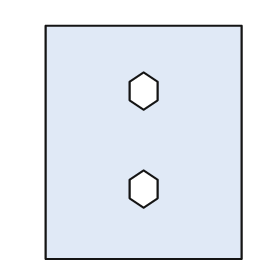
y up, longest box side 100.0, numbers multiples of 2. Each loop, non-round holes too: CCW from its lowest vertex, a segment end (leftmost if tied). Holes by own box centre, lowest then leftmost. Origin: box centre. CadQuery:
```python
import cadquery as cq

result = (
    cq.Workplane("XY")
    .moveTo(-42.0, -50.0)
    .lineTo(42.0, -50.0)
    .lineTo(42.0, 50.0)
    .lineTo(-42.0, 50.0)
    .close()
    .moveTo(0.0, -28.0)
    .lineTo(6.0, -24.0)
    .lineTo(6.0, -16.0)
    .lineTo(0.0, -12.0)
    .lineTo(-6.0, -16.0)
    .lineTo(-6.0, -24.0)
    .close()
    .moveTo(0.0, 14.0)
    .lineTo(6.0, 18.0)
    .lineTo(6.0, 26.0)
    .lineTo(0.0, 30.0)
    .lineTo(-6.0, 26.0)
    .lineTo(-6.0, 18.0)
    .close()
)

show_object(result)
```